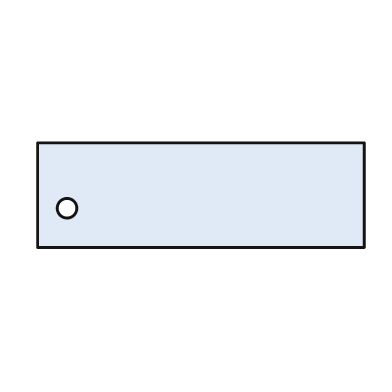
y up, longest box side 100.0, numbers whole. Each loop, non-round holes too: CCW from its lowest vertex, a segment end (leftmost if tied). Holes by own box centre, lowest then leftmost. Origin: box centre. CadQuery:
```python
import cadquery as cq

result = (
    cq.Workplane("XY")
    .moveTo(-50.0, -16.0)
    .lineTo(50.0, -16.0)
    .lineTo(50.0, 16.0)
    .lineTo(-50.0, 16.0)
    .close()
    .moveTo(-41.0, -4.0)
    .circle(3.0)
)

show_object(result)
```